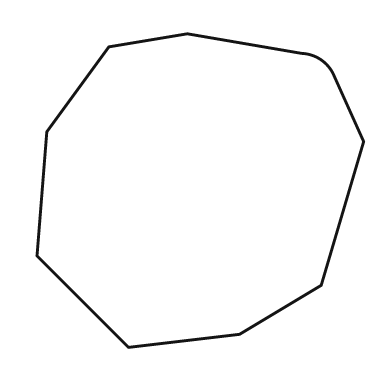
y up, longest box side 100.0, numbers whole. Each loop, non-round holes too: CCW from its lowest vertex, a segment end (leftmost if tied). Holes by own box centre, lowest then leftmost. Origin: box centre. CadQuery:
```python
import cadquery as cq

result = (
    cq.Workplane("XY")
    .moveTo(-22.0, -48.0)
    .lineTo(12.0, -44.0)
    .lineTo(37.0, -29.0)
    .lineTo(50.0, 15.0)
    .lineTo(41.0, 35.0)
    .threePointArc((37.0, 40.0), (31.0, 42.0))
    .lineTo(-4.0, 48.0)
    .lineTo(-28.0, 44.0)
    .lineTo(-47.0, 18.0)
    .lineTo(-50.0, -20.0)
    .close()
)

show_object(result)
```